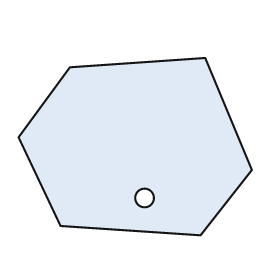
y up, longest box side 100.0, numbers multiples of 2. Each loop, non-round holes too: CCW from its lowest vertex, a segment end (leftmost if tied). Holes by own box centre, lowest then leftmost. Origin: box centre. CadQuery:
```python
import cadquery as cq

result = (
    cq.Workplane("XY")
    .moveTo(28.0, -38.0)
    .lineTo(50.0, -10.0)
    .lineTo(30.0, 38.0)
    .lineTo(-28.0, 34.0)
    .lineTo(-50.0, 4.0)
    .lineTo(-32.0, -34.0)
    .close()
    .moveTo(4.0, -22.0)
    .circle(4.0)
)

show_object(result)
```